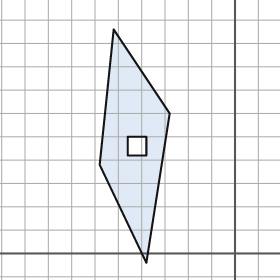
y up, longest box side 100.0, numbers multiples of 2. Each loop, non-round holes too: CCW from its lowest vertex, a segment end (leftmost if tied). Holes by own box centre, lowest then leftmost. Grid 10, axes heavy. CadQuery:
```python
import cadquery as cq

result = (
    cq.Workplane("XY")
    .moveTo(-38.0, -4.0)
    .lineTo(-28.0, 60.0)
    .lineTo(-52.0, 96.0)
    .lineTo(-58.0, 38.0)
    .close()
    .moveTo(-46.0, 42.0)
    .lineTo(-38.0, 42.0)
    .lineTo(-38.0, 50.0)
    .lineTo(-46.0, 50.0)
    .close()
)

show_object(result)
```